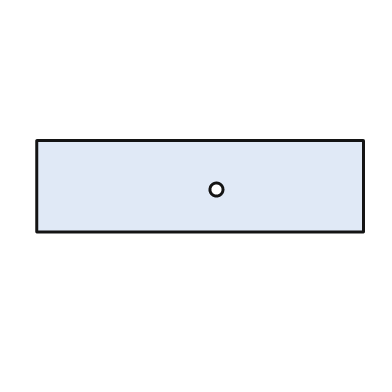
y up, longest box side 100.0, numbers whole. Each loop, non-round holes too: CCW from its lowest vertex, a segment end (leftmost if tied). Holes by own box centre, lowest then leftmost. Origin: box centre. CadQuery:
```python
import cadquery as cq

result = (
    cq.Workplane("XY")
    .moveTo(-50.0, -14.0)
    .lineTo(50.0, -14.0)
    .lineTo(50.0, 14.0)
    .lineTo(-50.0, 14.0)
    .close()
    .moveTo(5.0, -1.0)
    .circle(2.0)
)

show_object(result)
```